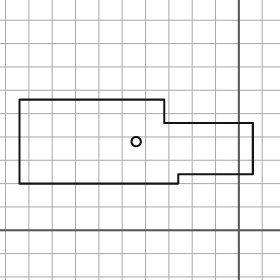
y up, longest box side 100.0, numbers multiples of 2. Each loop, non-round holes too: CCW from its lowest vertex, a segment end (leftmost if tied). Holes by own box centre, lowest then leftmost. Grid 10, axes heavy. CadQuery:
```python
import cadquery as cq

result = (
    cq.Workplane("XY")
    .moveTo(-94.0, 20.0)
    .lineTo(-26.0, 20.0)
    .lineTo(-26.0, 24.0)
    .lineTo(6.0, 24.0)
    .lineTo(6.0, 46.0)
    .lineTo(-32.0, 46.0)
    .lineTo(-32.0, 56.0)
    .lineTo(-94.0, 56.0)
    .close()
    .moveTo(-44.0, 38.0)
    .circle(2.0)
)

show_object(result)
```